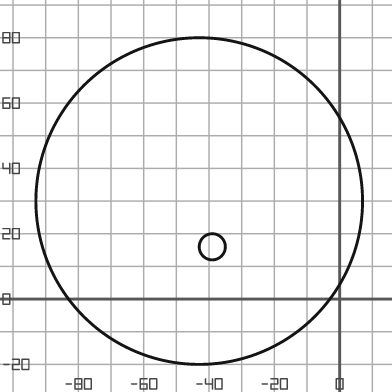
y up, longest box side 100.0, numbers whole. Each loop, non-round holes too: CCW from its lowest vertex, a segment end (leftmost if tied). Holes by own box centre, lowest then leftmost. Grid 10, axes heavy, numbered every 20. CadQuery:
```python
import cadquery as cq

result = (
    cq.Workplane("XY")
    .moveTo(-43.0, 30.0)
    .circle(50.0)
    .moveTo(-39.0, 16.0)
    .circle(4.0)
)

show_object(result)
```